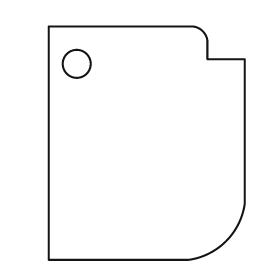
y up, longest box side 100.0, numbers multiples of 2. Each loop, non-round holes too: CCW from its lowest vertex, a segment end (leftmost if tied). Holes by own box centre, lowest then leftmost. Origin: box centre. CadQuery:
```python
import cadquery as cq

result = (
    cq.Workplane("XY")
    .moveTo(-42.0, -50.0)
    .lineTo(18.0, -50.0)
    .threePointArc((34.0, -42.0), (42.0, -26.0))
    .lineTo(42.0, 36.0)
    .lineTo(26.0, 36.0)
    .lineTo(26.0, 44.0)
    .threePointArc((24.0, 48.0), (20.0, 50.0))
    .lineTo(-42.0, 50.0)
    .close()
    .moveTo(-30.0, 34.0)
    .circle(6.0)
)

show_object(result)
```